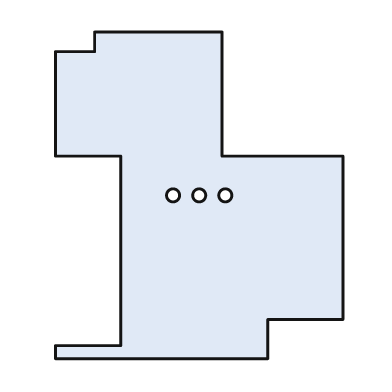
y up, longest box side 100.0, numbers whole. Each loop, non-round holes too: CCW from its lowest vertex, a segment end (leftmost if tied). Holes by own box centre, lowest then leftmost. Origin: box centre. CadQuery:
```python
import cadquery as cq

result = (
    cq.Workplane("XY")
    .moveTo(-44.0, -50.0)
    .lineTo(21.0, -50.0)
    .lineTo(21.0, -38.0)
    .lineTo(44.0, -38.0)
    .lineTo(44.0, 12.0)
    .lineTo(7.0, 12.0)
    .lineTo(7.0, 50.0)
    .lineTo(-32.0, 50.0)
    .lineTo(-32.0, 44.0)
    .lineTo(-44.0, 44.0)
    .lineTo(-44.0, 12.0)
    .lineTo(-24.0, 12.0)
    .lineTo(-24.0, -46.0)
    .lineTo(-44.0, -46.0)
    .close()
    .moveTo(-8.0, 0.0)
    .circle(2.0)
    .moveTo(0.0, 0.0)
    .circle(2.0)
    .moveTo(8.0, 0.0)
    .circle(2.0)
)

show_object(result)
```